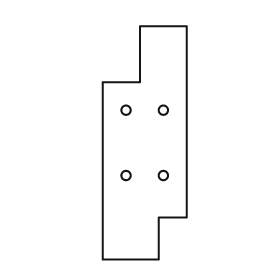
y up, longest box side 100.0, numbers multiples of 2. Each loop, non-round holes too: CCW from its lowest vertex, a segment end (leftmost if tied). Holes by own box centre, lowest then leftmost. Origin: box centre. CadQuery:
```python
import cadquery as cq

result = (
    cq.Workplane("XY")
    .moveTo(-18.0, -50.0)
    .lineTo(6.0, -50.0)
    .lineTo(6.0, -32.0)
    .lineTo(18.0, -32.0)
    .lineTo(18.0, 50.0)
    .lineTo(-2.0, 50.0)
    .lineTo(-2.0, 26.0)
    .lineTo(-18.0, 26.0)
    .close()
    .moveTo(-8.0, -14.0)
    .circle(2.0)
    .moveTo(8.0, -14.0)
    .circle(2.0)
    .moveTo(-8.0, 14.0)
    .circle(2.0)
    .moveTo(8.0, 14.0)
    .circle(2.0)
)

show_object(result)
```